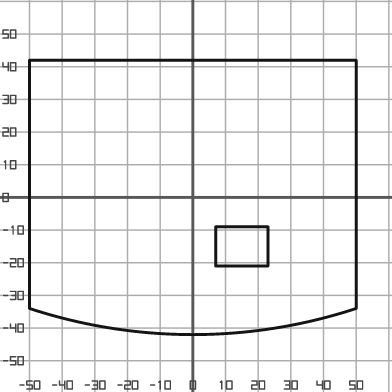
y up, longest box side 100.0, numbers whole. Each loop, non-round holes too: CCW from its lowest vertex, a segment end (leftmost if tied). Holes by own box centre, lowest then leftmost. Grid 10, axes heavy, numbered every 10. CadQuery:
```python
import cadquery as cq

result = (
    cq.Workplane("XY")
    .moveTo(-50.0, -34.0)
    .threePointArc((0.0, -42.0), (50.0, -34.0))
    .lineTo(50.0, 42.0)
    .lineTo(-50.0, 42.0)
    .close()
    .moveTo(7.0, -21.0)
    .lineTo(23.0, -21.0)
    .lineTo(23.0, -9.0)
    .lineTo(7.0, -9.0)
    .close()
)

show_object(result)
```